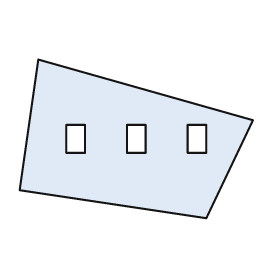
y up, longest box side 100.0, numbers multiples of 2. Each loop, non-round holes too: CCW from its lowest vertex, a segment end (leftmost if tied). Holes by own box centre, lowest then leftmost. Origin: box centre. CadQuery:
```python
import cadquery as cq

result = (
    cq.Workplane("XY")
    .moveTo(30.0, -34.0)
    .lineTo(50.0, 8.0)
    .lineTo(-42.0, 34.0)
    .lineTo(-50.0, -22.0)
    .close()
    .moveTo(-30.0, -6.0)
    .lineTo(-22.0, -6.0)
    .lineTo(-22.0, 6.0)
    .lineTo(-30.0, 6.0)
    .close()
    .moveTo(-4.0, -6.0)
    .lineTo(4.0, -6.0)
    .lineTo(4.0, 6.0)
    .lineTo(-4.0, 6.0)
    .close()
    .moveTo(22.0, -6.0)
    .lineTo(30.0, -6.0)
    .lineTo(30.0, 6.0)
    .lineTo(22.0, 6.0)
    .close()
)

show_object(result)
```